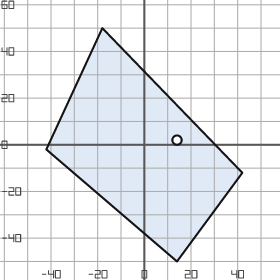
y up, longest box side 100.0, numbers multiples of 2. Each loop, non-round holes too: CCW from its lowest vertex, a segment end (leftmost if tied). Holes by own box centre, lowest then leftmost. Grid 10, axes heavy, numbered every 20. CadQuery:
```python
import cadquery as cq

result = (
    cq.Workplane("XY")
    .moveTo(14.0, -50.0)
    .lineTo(42.0, -12.0)
    .lineTo(-18.0, 50.0)
    .lineTo(-42.0, -2.0)
    .close()
    .moveTo(14.0, 2.0)
    .circle(2.0)
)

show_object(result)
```